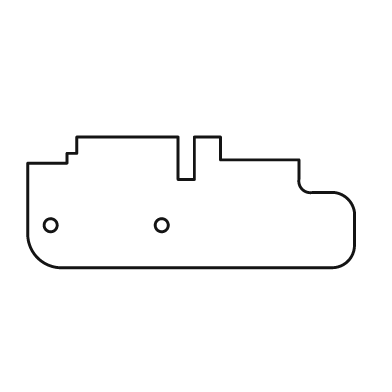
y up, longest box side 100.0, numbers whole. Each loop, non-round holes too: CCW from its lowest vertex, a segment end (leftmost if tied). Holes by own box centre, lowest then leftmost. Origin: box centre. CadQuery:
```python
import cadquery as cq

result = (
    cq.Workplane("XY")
    .moveTo(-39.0, -20.0)
    .lineTo(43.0, -20.0)
    .threePointArc((48.0, -18.0), (50.0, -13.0))
    .lineTo(50.0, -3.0)
    .threePointArc((48.0, 1.0), (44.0, 3.0))
    .lineTo(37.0, 3.0)
    .threePointArc((34.0, 4.0), (33.0, 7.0))
    .lineTo(33.0, 13.0)
    .lineTo(9.0, 13.0)
    .lineTo(9.0, 20.0)
    .lineTo(1.0, 20.0)
    .lineTo(1.0, 7.0)
    .lineTo(-4.0, 7.0)
    .lineTo(-4.0, 20.0)
    .lineTo(-35.0, 20.0)
    .lineTo(-35.0, 15.0)
    .lineTo(-38.0, 15.0)
    .lineTo(-38.0, 12.0)
    .lineTo(-50.0, 12.0)
    .lineTo(-50.0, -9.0)
    .threePointArc((-47.0, -17.0), (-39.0, -20.0))
    .close()
    .moveTo(-43.0, -7.0)
    .circle(2.0)
    .moveTo(-9.0, -7.0)
    .circle(2.0)
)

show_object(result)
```